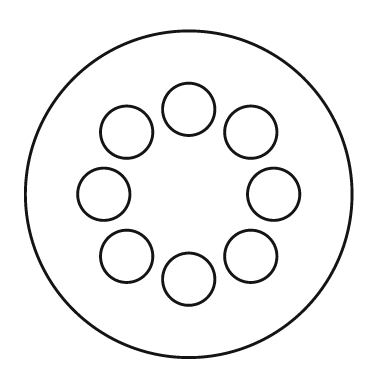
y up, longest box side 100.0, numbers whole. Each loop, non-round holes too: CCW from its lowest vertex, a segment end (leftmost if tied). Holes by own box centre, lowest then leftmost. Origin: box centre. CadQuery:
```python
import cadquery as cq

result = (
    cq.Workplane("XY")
    .moveTo(0.0, 0.0)
    .circle(50.0)
    .moveTo(0.0, -26.0)
    .circle(8.0)
    .moveTo(-19.0, -19.0)
    .circle(8.0)
    .moveTo(19.0, -19.0)
    .circle(8.0)
    .moveTo(-26.0, 0.0)
    .circle(8.0)
    .moveTo(26.0, 0.0)
    .circle(8.0)
    .moveTo(-19.0, 19.0)
    .circle(8.0)
    .moveTo(19.0, 19.0)
    .circle(8.0)
    .moveTo(0.0, 26.0)
    .circle(8.0)
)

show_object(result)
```